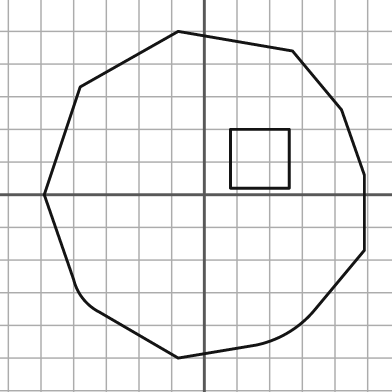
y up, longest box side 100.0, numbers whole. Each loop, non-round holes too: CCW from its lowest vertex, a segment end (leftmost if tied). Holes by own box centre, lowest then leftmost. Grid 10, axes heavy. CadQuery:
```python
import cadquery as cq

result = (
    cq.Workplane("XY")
    .moveTo(-8.0, -50.0)
    .lineTo(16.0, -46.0)
    .threePointArc((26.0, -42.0), (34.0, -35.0))
    .lineTo(49.0, -17.0)
    .lineTo(49.0, 6.0)
    .lineTo(42.0, 26.0)
    .lineTo(27.0, 44.0)
    .lineTo(-8.0, 50.0)
    .lineTo(-38.0, 33.0)
    .lineTo(-49.0, 0.0)
    .lineTo(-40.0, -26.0)
    .threePointArc((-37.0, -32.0), (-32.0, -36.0))
    .close()
    .moveTo(8.0, 2.0)
    .lineTo(26.0, 2.0)
    .lineTo(26.0, 20.0)
    .lineTo(8.0, 20.0)
    .close()
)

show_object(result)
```